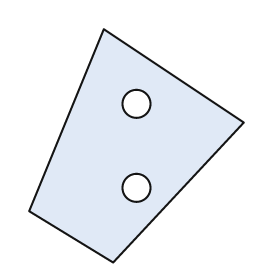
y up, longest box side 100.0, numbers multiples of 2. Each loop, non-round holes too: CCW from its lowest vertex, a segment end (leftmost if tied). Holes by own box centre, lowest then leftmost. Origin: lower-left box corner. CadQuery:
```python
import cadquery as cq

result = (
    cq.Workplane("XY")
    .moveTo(36.0, 0.0)
    .lineTo(92.0, 60.0)
    .lineTo(32.0, 100.0)
    .lineTo(0.0, 22.0)
    .close()
    .moveTo(46.0, 32.0)
    .circle(6.0)
    .moveTo(46.0, 68.0)
    .circle(6.0)
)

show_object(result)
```